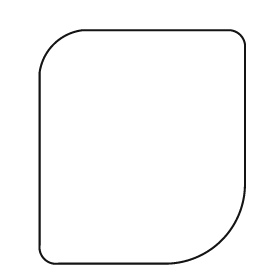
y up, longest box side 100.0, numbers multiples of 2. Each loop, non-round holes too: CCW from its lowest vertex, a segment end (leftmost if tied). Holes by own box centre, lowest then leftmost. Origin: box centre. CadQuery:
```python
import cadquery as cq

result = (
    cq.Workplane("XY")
    .moveTo(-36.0, -50.0)
    .lineTo(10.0, -50.0)
    .threePointArc((34.0, -40.0), (44.0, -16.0))
    .lineTo(44.0, 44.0)
    .threePointArc((42.0, 48.0), (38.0, 50.0))
    .lineTo(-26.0, 50.0)
    .threePointArc((-38.0, 44.0), (-44.0, 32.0))
    .lineTo(-44.0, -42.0)
    .threePointArc((-42.0, -48.0), (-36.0, -50.0))
    .close()
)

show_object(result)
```